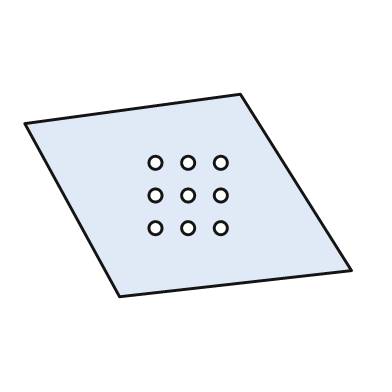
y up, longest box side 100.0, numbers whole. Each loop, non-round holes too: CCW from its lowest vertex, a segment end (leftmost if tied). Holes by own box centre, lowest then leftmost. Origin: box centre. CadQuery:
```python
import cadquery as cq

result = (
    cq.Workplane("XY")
    .moveTo(-21.0, -31.0)
    .lineTo(50.0, -23.0)
    .lineTo(16.0, 31.0)
    .lineTo(-50.0, 22.0)
    .close()
    .moveTo(-10.0, -10.0)
    .circle(2.0)
    .moveTo(0.0, -10.0)
    .circle(2.0)
    .moveTo(10.0, -10.0)
    .circle(2.0)
    .moveTo(-10.0, 0.0)
    .circle(2.0)
    .moveTo(0.0, 0.0)
    .circle(2.0)
    .moveTo(10.0, 0.0)
    .circle(2.0)
    .moveTo(-10.0, 10.0)
    .circle(2.0)
    .moveTo(0.0, 10.0)
    .circle(2.0)
    .moveTo(10.0, 10.0)
    .circle(2.0)
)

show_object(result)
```